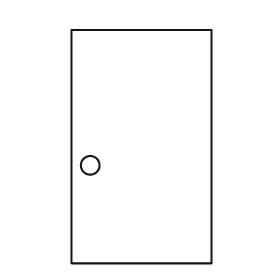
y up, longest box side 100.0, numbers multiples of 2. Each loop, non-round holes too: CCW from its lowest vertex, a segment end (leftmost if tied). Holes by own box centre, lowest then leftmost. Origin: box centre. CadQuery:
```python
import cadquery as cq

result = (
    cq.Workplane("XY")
    .moveTo(-30.0, -50.0)
    .lineTo(30.0, -50.0)
    .lineTo(30.0, 50.0)
    .lineTo(-30.0, 50.0)
    .close()
    .moveTo(-22.0, -8.0)
    .circle(4.0)
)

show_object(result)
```